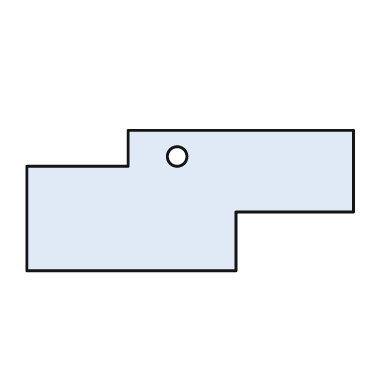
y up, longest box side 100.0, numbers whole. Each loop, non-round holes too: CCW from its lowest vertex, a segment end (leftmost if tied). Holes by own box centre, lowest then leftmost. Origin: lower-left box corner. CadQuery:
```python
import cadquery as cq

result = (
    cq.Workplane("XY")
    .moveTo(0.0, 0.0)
    .lineTo(64.0, 0.0)
    .lineTo(64.0, 18.0)
    .lineTo(100.0, 18.0)
    .lineTo(100.0, 43.0)
    .lineTo(31.0, 43.0)
    .lineTo(31.0, 32.0)
    .lineTo(0.0, 32.0)
    .close()
    .moveTo(46.0, 35.0)
    .circle(3.0)
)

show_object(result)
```